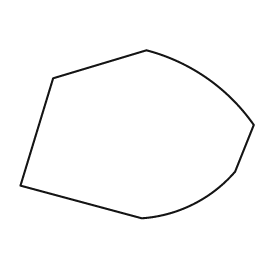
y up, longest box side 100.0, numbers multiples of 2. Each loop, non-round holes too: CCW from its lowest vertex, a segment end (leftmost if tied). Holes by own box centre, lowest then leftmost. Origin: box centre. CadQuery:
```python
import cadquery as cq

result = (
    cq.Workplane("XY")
    .moveTo(2.0, -36.0)
    .threePointArc((24.0, -30.0), (42.0, -16.0))
    .lineTo(50.0, 4.0)
    .threePointArc((30.0, 24.0), (4.0, 36.0))
    .lineTo(-36.0, 24.0)
    .lineTo(-50.0, -22.0)
    .close()
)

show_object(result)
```